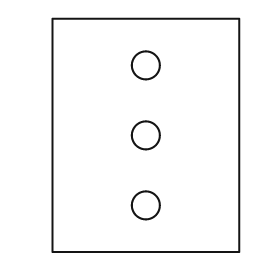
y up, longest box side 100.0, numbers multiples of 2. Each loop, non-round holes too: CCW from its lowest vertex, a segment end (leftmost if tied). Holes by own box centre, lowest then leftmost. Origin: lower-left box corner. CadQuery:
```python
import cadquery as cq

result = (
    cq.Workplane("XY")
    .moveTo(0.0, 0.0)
    .lineTo(80.0, 0.0)
    .lineTo(80.0, 100.0)
    .lineTo(0.0, 100.0)
    .close()
    .moveTo(40.0, 20.0)
    .circle(6.0)
    .moveTo(40.0, 50.0)
    .circle(6.0)
    .moveTo(40.0, 80.0)
    .circle(6.0)
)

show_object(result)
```